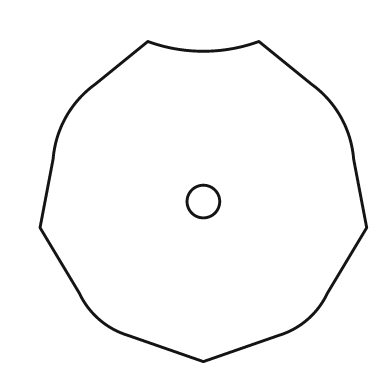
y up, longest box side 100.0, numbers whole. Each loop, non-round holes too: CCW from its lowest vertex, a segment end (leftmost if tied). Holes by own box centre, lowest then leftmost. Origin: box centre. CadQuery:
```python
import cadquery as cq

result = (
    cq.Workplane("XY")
    .moveTo(0.0, -49.0)
    .lineTo(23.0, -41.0)
    .threePointArc((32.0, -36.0), (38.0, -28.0))
    .lineTo(50.0, -8.0)
    .lineTo(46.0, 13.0)
    .threePointArc((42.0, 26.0), (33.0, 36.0))
    .lineTo(17.0, 49.0)
    .threePointArc((0.0, 46.0), (-17.0, 49.0))
    .lineTo(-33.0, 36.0)
    .threePointArc((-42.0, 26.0), (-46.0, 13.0))
    .lineTo(-50.0, -8.0)
    .lineTo(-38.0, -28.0)
    .threePointArc((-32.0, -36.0), (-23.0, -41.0))
    .close()
    .moveTo(0.0, 0.0)
    .circle(5.0)
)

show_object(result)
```